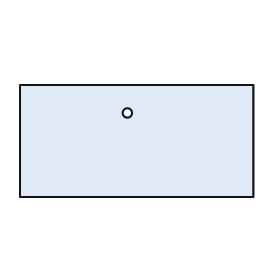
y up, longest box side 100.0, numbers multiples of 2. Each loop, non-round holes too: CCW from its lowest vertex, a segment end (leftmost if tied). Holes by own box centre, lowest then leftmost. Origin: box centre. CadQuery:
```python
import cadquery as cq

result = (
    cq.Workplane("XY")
    .moveTo(-50.0, -24.0)
    .lineTo(50.0, -24.0)
    .lineTo(50.0, 24.0)
    .lineTo(-50.0, 24.0)
    .close()
    .moveTo(-4.0, 12.0)
    .circle(2.0)
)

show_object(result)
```